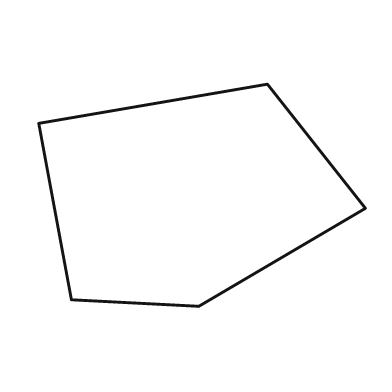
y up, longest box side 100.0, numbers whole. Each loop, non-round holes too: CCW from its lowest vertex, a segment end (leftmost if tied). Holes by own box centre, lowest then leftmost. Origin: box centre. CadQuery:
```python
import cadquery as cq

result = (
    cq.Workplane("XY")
    .moveTo(-1.0, -34.0)
    .lineTo(50.0, -4.0)
    .lineTo(20.0, 34.0)
    .lineTo(-50.0, 22.0)
    .lineTo(-40.0, -32.0)
    .close()
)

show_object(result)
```